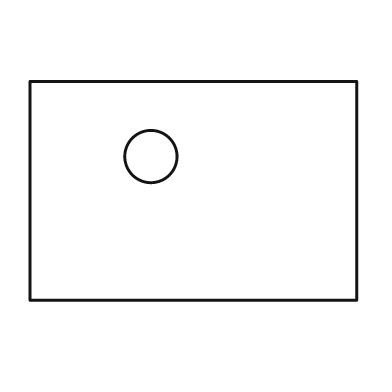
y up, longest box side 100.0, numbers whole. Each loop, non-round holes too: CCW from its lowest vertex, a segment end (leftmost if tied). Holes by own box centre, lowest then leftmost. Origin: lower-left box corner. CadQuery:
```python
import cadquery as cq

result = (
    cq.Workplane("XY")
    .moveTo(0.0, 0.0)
    .lineTo(100.0, 0.0)
    .lineTo(100.0, 67.0)
    .lineTo(0.0, 67.0)
    .close()
    .moveTo(37.0, 44.0)
    .circle(8.0)
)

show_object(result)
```